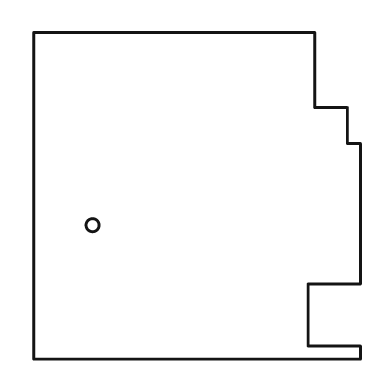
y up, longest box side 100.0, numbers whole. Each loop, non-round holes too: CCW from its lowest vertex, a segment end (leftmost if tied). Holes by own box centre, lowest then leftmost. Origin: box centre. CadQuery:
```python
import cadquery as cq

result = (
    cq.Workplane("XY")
    .moveTo(-50.0, -50.0)
    .lineTo(50.0, -50.0)
    .lineTo(50.0, -46.0)
    .lineTo(34.0, -46.0)
    .lineTo(34.0, -27.0)
    .lineTo(50.0, -27.0)
    .lineTo(50.0, 16.0)
    .lineTo(46.0, 16.0)
    .lineTo(46.0, 27.0)
    .lineTo(36.0, 27.0)
    .lineTo(36.0, 50.0)
    .lineTo(-50.0, 50.0)
    .close()
    .moveTo(-32.0, -9.0)
    .circle(2.0)
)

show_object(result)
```